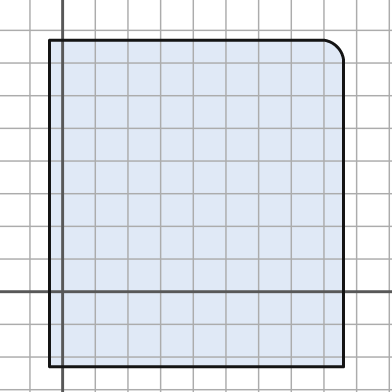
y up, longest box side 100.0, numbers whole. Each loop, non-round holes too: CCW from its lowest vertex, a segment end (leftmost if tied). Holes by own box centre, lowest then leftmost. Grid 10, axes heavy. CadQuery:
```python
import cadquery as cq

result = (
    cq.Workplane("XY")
    .moveTo(-4.0, -23.0)
    .lineTo(86.0, -23.0)
    .lineTo(86.0, 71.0)
    .threePointArc((84.0, 75.0), (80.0, 77.0))
    .lineTo(-4.0, 77.0)
    .close()
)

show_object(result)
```